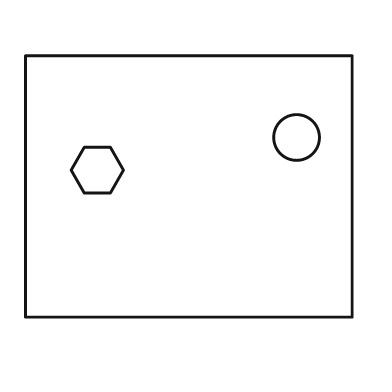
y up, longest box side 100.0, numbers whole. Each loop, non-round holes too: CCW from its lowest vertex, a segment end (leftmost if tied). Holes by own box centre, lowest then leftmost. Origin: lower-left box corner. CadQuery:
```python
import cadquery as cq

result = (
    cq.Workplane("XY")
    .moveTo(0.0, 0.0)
    .lineTo(100.0, 0.0)
    .lineTo(100.0, 80.0)
    .lineTo(0.0, 80.0)
    .close()
    .moveTo(18.0, 38.0)
    .lineTo(26.0, 38.0)
    .lineTo(30.0, 45.0)
    .lineTo(26.0, 52.0)
    .lineTo(18.0, 52.0)
    .lineTo(14.0, 45.0)
    .close()
    .moveTo(83.0, 55.0)
    .circle(7.0)
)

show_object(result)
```